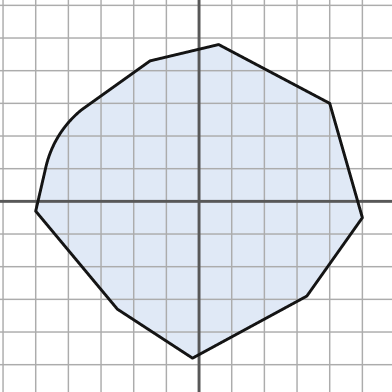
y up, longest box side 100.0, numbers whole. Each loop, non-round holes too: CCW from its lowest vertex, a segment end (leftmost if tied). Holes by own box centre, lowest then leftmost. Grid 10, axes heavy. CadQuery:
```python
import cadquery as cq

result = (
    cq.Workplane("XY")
    .moveTo(-2.0, -48.0)
    .lineTo(33.0, -29.0)
    .lineTo(50.0, -5.0)
    .lineTo(40.0, 30.0)
    .lineTo(6.0, 48.0)
    .lineTo(-15.0, 43.0)
    .lineTo(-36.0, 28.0)
    .threePointArc((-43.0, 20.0), (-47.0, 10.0))
    .lineTo(-50.0, -3.0)
    .lineTo(-25.0, -33.0)
    .close()
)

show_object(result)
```